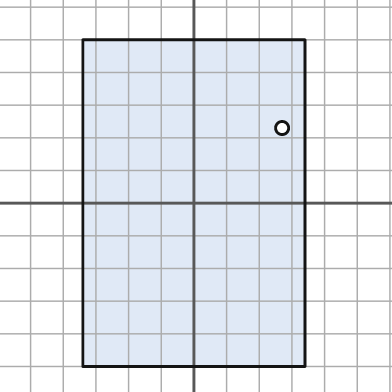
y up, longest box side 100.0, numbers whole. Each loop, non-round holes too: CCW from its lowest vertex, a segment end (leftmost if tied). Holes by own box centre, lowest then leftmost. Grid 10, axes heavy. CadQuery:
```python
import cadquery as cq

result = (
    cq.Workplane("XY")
    .moveTo(-34.0, -50.0)
    .lineTo(34.0, -50.0)
    .lineTo(34.0, 50.0)
    .lineTo(-34.0, 50.0)
    .close()
    .moveTo(27.0, 23.0)
    .circle(2.0)
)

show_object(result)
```